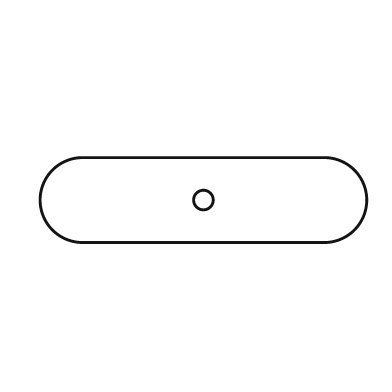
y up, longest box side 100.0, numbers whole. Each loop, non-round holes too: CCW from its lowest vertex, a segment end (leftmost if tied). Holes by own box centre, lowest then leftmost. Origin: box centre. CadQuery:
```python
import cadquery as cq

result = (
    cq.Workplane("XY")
    .moveTo(-37.0, -13.0)
    .lineTo(37.0, -13.0)
    .threePointArc((50.0, 0.0), (37.0, 13.0))
    .lineTo(-37.0, 13.0)
    .threePointArc((-50.0, 0.0), (-37.0, -13.0))
    .close()
    .moveTo(0.0, 0.0)
    .circle(3.0)
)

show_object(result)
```